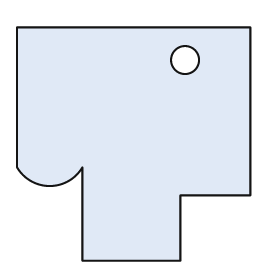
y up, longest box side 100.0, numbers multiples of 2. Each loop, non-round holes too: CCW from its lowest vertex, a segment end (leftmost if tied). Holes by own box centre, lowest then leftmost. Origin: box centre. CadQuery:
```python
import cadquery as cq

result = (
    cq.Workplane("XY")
    .moveTo(-22.0, -50.0)
    .lineTo(20.0, -50.0)
    .lineTo(20.0, -22.0)
    .lineTo(50.0, -22.0)
    .lineTo(50.0, 50.0)
    .lineTo(-50.0, 50.0)
    .lineTo(-50.0, -10.0)
    .threePointArc((-36.0, -18.0), (-22.0, -10.0))
    .close()
    .moveTo(22.0, 36.0)
    .circle(6.0)
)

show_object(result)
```